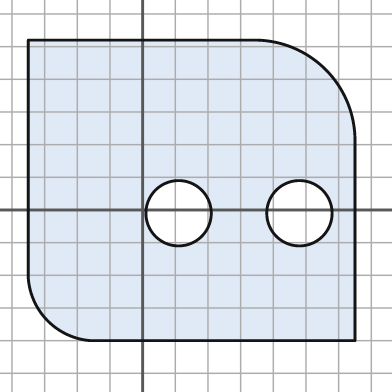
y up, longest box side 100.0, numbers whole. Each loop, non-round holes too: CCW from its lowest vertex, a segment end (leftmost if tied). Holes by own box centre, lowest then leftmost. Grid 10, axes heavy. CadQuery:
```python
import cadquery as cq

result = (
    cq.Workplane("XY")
    .moveTo(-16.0, -40.0)
    .lineTo(65.0, -40.0)
    .lineTo(65.0, 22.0)
    .threePointArc((56.0, 43.0), (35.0, 52.0))
    .lineTo(-35.0, 52.0)
    .lineTo(-35.0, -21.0)
    .threePointArc((-29.0, -34.0), (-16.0, -40.0))
    .close()
    .moveTo(11.0, -1.0)
    .circle(10.0)
    .moveTo(48.0, -1.0)
    .circle(10.0)
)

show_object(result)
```